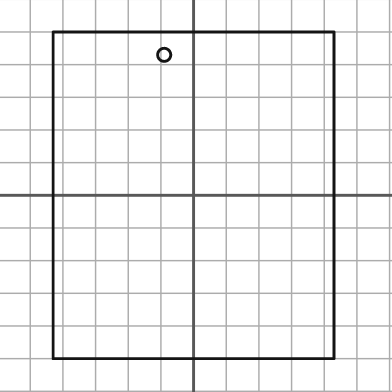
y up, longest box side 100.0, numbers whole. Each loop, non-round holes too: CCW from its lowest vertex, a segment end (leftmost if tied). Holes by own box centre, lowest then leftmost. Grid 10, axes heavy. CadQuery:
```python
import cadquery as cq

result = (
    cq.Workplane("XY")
    .moveTo(-43.0, -50.0)
    .lineTo(43.0, -50.0)
    .lineTo(43.0, 50.0)
    .lineTo(-43.0, 50.0)
    .close()
    .moveTo(-9.0, 43.0)
    .circle(2.0)
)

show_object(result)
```